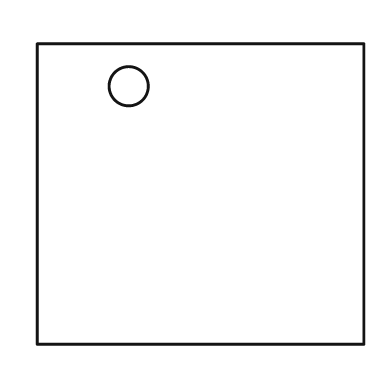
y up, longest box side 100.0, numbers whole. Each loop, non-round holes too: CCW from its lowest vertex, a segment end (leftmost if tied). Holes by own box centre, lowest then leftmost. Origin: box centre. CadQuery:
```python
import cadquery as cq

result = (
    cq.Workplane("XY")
    .moveTo(-50.0, -46.0)
    .lineTo(50.0, -46.0)
    .lineTo(50.0, 46.0)
    .lineTo(-50.0, 46.0)
    .close()
    .moveTo(-22.0, 33.0)
    .circle(6.0)
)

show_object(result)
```